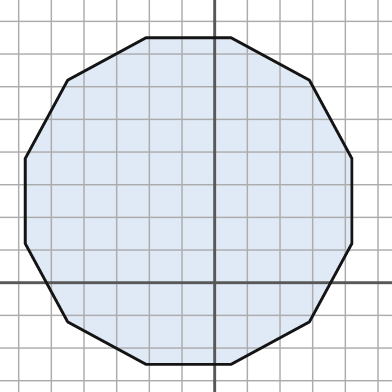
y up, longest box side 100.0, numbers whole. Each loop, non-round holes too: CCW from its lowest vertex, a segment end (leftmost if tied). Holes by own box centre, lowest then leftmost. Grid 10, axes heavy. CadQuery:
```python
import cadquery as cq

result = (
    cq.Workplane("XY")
    .moveTo(-21.0, -25.0)
    .lineTo(5.0, -25.0)
    .lineTo(29.0, -12.0)
    .lineTo(42.0, 12.0)
    .lineTo(42.0, 38.0)
    .lineTo(29.0, 62.0)
    .lineTo(5.0, 75.0)
    .lineTo(-21.0, 75.0)
    .lineTo(-45.0, 62.0)
    .lineTo(-58.0, 38.0)
    .lineTo(-58.0, 12.0)
    .lineTo(-45.0, -12.0)
    .close()
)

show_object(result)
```